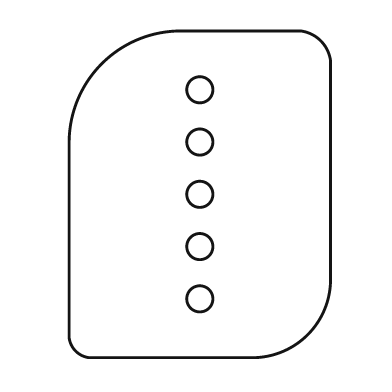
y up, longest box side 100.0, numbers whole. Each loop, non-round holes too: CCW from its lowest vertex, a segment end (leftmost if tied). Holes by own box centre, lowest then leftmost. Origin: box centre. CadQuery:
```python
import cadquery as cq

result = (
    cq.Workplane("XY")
    .moveTo(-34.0, -50.0)
    .lineTo(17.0, -50.0)
    .threePointArc((33.0, -43.0), (40.0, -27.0))
    .lineTo(40.0, 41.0)
    .threePointArc((37.0, 47.0), (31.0, 50.0))
    .lineTo(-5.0, 50.0)
    .threePointArc((-30.0, 40.0), (-40.0, 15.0))
    .lineTo(-40.0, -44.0)
    .threePointArc((-38.0, -48.0), (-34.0, -50.0))
    .close()
    .moveTo(0.0, -32.0)
    .circle(4.0)
    .moveTo(0.0, -16.0)
    .circle(4.0)
    .moveTo(0.0, 0.0)
    .circle(4.0)
    .moveTo(0.0, 16.0)
    .circle(4.0)
    .moveTo(0.0, 32.0)
    .circle(4.0)
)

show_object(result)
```